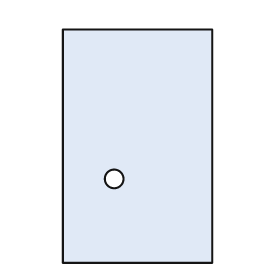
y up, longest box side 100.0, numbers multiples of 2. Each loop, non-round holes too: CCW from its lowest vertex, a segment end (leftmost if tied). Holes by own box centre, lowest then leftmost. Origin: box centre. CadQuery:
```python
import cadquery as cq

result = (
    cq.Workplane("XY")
    .moveTo(-32.0, -50.0)
    .lineTo(32.0, -50.0)
    .lineTo(32.0, 50.0)
    .lineTo(-32.0, 50.0)
    .close()
    .moveTo(-10.0, -14.0)
    .circle(4.0)
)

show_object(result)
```